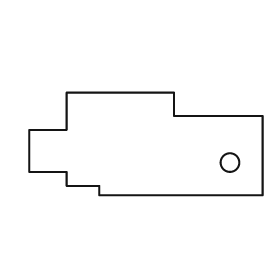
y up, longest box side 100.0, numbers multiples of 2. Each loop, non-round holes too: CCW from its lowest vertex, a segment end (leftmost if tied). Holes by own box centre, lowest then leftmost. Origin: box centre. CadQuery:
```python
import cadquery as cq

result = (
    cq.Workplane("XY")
    .moveTo(-20.0, -22.0)
    .lineTo(50.0, -22.0)
    .lineTo(50.0, 12.0)
    .lineTo(12.0, 12.0)
    .lineTo(12.0, 22.0)
    .lineTo(-34.0, 22.0)
    .lineTo(-34.0, 6.0)
    .lineTo(-50.0, 6.0)
    .lineTo(-50.0, -12.0)
    .lineTo(-34.0, -12.0)
    .lineTo(-34.0, -18.0)
    .lineTo(-20.0, -18.0)
    .close()
    .moveTo(36.0, -8.0)
    .circle(4.0)
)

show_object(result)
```